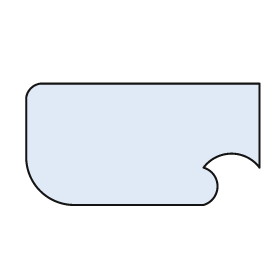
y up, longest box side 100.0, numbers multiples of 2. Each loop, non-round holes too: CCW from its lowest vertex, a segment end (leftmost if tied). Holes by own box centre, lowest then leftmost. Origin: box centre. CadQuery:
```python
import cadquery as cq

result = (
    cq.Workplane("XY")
    .moveTo(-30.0, -26.0)
    .lineTo(26.0, -26.0)
    .threePointArc((32.0, -18.0), (26.0, -10.0))
    .threePointArc((38.0, -4.0), (50.0, -10.0))
    .lineTo(50.0, 26.0)
    .lineTo(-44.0, 26.0)
    .threePointArc((-48.0, 24.0), (-50.0, 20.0))
    .lineTo(-50.0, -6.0)
    .threePointArc((-44.0, -20.0), (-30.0, -26.0))
    .close()
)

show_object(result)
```